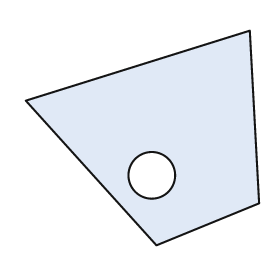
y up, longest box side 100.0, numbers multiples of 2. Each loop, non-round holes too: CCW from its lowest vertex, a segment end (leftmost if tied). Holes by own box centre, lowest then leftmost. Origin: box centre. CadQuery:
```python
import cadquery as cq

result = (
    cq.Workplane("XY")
    .moveTo(6.0, -46.0)
    .lineTo(50.0, -28.0)
    .lineTo(46.0, 46.0)
    .lineTo(-50.0, 16.0)
    .close()
    .moveTo(4.0, -16.0)
    .circle(10.0)
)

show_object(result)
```